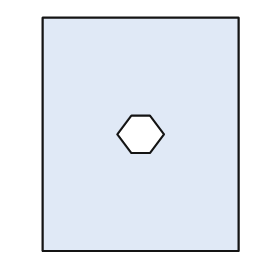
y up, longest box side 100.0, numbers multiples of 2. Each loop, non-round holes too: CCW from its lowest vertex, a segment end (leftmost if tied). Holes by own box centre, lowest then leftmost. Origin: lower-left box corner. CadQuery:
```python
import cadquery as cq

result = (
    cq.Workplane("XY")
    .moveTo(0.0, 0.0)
    .lineTo(84.0, 0.0)
    .lineTo(84.0, 100.0)
    .lineTo(0.0, 100.0)
    .close()
    .moveTo(38.0, 42.0)
    .lineTo(46.0, 42.0)
    .lineTo(52.0, 50.0)
    .lineTo(46.0, 58.0)
    .lineTo(38.0, 58.0)
    .lineTo(32.0, 50.0)
    .close()
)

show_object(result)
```